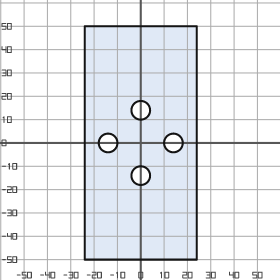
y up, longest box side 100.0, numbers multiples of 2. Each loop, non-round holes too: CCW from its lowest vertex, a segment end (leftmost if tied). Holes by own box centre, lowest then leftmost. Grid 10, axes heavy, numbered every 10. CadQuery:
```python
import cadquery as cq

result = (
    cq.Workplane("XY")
    .moveTo(-24.0, -50.0)
    .lineTo(24.0, -50.0)
    .lineTo(24.0, 50.0)
    .lineTo(-24.0, 50.0)
    .close()
    .moveTo(0.0, -14.0)
    .circle(4.0)
    .moveTo(-14.0, 0.0)
    .circle(4.0)
    .moveTo(14.0, 0.0)
    .circle(4.0)
    .moveTo(0.0, 14.0)
    .circle(4.0)
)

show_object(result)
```